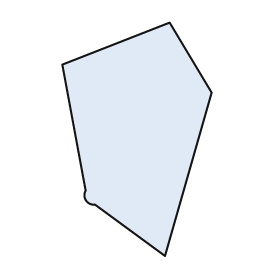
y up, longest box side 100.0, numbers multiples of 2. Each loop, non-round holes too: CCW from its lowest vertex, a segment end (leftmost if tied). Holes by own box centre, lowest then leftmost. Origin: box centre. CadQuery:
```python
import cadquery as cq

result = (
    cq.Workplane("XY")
    .moveTo(12.0, -50.0)
    .lineTo(32.0, 20.0)
    .lineTo(14.0, 50.0)
    .lineTo(-32.0, 32.0)
    .lineTo(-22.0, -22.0)
    .threePointArc((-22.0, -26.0), (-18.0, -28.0))
    .close()
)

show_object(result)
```